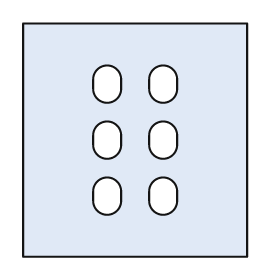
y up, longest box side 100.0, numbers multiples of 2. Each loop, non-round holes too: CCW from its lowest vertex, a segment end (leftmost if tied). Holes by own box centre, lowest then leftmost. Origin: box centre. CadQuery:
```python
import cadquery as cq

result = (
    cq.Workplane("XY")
    .moveTo(-48.0, -50.0)
    .lineTo(48.0, -50.0)
    .lineTo(48.0, 50.0)
    .lineTo(-48.0, 50.0)
    .close()
    .moveTo(-18.0, -26.0)
    .threePointArc((-12.0, -32.0), (-6.0, -26.0))
    .lineTo(-6.0, -22.0)
    .threePointArc((-12.0, -16.0), (-18.0, -22.0))
    .close()
    .moveTo(6.0, -26.0)
    .threePointArc((12.0, -32.0), (18.0, -26.0))
    .lineTo(18.0, -22.0)
    .threePointArc((12.0, -16.0), (6.0, -22.0))
    .close()
    .moveTo(-18.0, -2.0)
    .threePointArc((-12.0, -8.0), (-6.0, -2.0))
    .lineTo(-6.0, 2.0)
    .threePointArc((-12.0, 8.0), (-18.0, 2.0))
    .close()
    .moveTo(6.0, -2.0)
    .threePointArc((12.0, -8.0), (18.0, -2.0))
    .lineTo(18.0, 2.0)
    .threePointArc((12.0, 8.0), (6.0, 2.0))
    .close()
    .moveTo(-18.0, 22.0)
    .threePointArc((-12.0, 16.0), (-6.0, 22.0))
    .lineTo(-6.0, 26.0)
    .threePointArc((-12.0, 32.0), (-18.0, 26.0))
    .close()
    .moveTo(6.0, 22.0)
    .threePointArc((12.0, 16.0), (18.0, 22.0))
    .lineTo(18.0, 26.0)
    .threePointArc((12.0, 32.0), (6.0, 26.0))
    .close()
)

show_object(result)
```